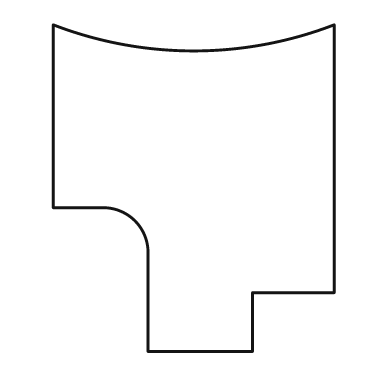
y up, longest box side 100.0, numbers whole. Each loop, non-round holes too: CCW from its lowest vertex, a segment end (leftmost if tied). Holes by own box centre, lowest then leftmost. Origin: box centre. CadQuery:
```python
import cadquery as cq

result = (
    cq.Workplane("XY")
    .moveTo(-14.0, -50.0)
    .lineTo(18.0, -50.0)
    .lineTo(18.0, -32.0)
    .lineTo(43.0, -32.0)
    .lineTo(43.0, 50.0)
    .threePointArc((0.0, 42.0), (-43.0, 50.0))
    .lineTo(-43.0, -6.0)
    .lineTo(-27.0, -6.0)
    .threePointArc((-18.0, -10.0), (-14.0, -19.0))
    .close()
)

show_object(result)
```